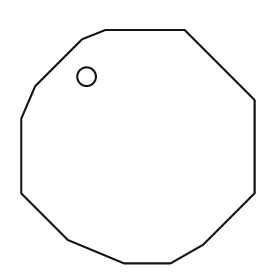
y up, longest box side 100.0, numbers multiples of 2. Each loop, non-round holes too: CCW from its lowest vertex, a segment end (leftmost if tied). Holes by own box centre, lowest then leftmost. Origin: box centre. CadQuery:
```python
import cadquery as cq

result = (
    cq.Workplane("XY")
    .moveTo(-6.0, -50.0)
    .lineTo(14.0, -50.0)
    .lineTo(28.0, -42.0)
    .lineTo(50.0, -20.0)
    .lineTo(50.0, 20.0)
    .lineTo(20.0, 50.0)
    .lineTo(-14.0, 50.0)
    .lineTo(-24.0, 46.0)
    .lineTo(-44.0, 26.0)
    .lineTo(-50.0, 12.0)
    .lineTo(-50.0, -20.0)
    .lineTo(-30.0, -40.0)
    .close()
    .moveTo(-22.0, 30.0)
    .circle(4.0)
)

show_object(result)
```